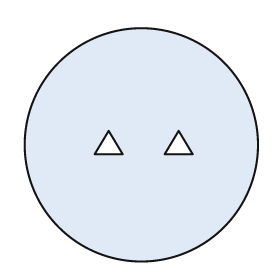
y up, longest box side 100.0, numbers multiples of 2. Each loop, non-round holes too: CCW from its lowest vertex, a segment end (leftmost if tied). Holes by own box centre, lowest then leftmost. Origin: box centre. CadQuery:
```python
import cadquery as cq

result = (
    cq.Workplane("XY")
    .moveTo(0.0, 0.0)
    .circle(50.0)
    .moveTo(-20.0, -4.0)
    .lineTo(-8.0, -4.0)
    .lineTo(-14.0, 6.0)
    .close()
    .moveTo(10.0, -4.0)
    .lineTo(22.0, -4.0)
    .lineTo(16.0, 6.0)
    .close()
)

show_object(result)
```